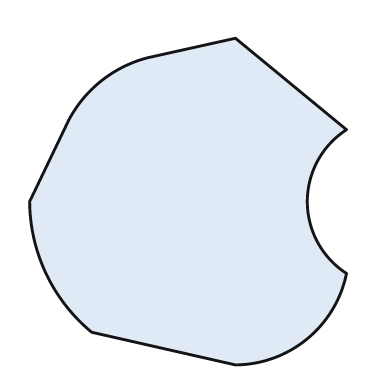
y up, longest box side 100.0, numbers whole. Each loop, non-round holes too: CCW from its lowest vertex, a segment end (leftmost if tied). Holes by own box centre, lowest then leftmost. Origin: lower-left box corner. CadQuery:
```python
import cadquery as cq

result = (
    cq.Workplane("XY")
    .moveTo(63.0, 0.0)
    .threePointArc((85.0, 8.0), (97.0, 28.0))
    .threePointArc((85.0, 50.0), (97.0, 72.0))
    .lineTo(63.0, 100.0)
    .lineTo(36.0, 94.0)
    .threePointArc((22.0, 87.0), (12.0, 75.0))
    .lineTo(0.0, 50.0)
    .threePointArc((5.0, 28.0), (19.0, 10.0))
    .close()
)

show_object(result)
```